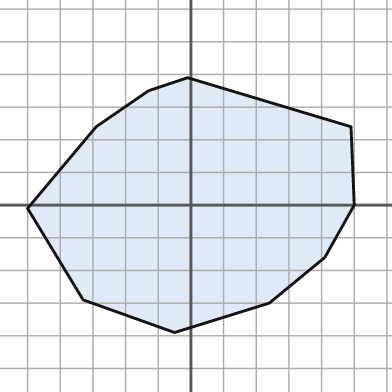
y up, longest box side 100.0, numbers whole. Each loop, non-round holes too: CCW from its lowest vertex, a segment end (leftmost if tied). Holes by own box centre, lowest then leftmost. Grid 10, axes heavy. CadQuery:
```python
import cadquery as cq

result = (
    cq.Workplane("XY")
    .moveTo(-5.0, -39.0)
    .lineTo(24.0, -30.0)
    .lineTo(41.0, -16.0)
    .lineTo(50.0, 0.0)
    .lineTo(49.0, 24.0)
    .lineTo(-1.0, 39.0)
    .lineTo(-13.0, 35.0)
    .lineTo(-29.0, 24.0)
    .lineTo(-50.0, -1.0)
    .lineTo(-33.0, -29.0)
    .close()
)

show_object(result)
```